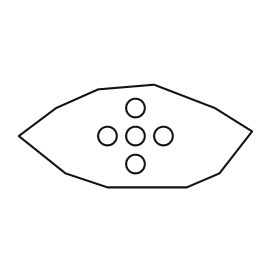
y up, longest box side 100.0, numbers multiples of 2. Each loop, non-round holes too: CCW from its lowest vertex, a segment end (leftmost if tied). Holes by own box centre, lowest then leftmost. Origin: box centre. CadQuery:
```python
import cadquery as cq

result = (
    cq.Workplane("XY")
    .moveTo(-12.0, -22.0)
    .lineTo(22.0, -22.0)
    .lineTo(36.0, -16.0)
    .lineTo(50.0, 2.0)
    .lineTo(34.0, 12.0)
    .lineTo(8.0, 22.0)
    .lineTo(-16.0, 20.0)
    .lineTo(-34.0, 12.0)
    .lineTo(-50.0, 0.0)
    .lineTo(-30.0, -16.0)
    .close()
    .moveTo(0.0, -12.0)
    .circle(4.0)
    .moveTo(-12.0, 0.0)
    .circle(4.0)
    .moveTo(0.0, 0.0)
    .circle(4.0)
    .moveTo(12.0, 0.0)
    .circle(4.0)
    .moveTo(0.0, 12.0)
    .circle(4.0)
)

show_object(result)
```